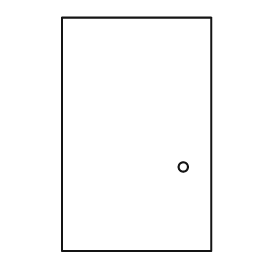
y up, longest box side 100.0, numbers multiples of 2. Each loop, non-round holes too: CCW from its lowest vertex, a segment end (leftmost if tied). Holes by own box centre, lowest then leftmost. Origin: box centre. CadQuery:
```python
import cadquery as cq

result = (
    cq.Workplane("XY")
    .moveTo(-32.0, -50.0)
    .lineTo(32.0, -50.0)
    .lineTo(32.0, 50.0)
    .lineTo(-32.0, 50.0)
    .close()
    .moveTo(20.0, -14.0)
    .circle(2.0)
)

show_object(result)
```